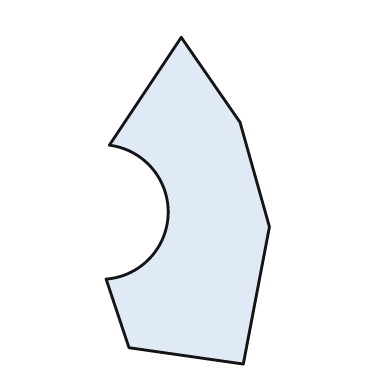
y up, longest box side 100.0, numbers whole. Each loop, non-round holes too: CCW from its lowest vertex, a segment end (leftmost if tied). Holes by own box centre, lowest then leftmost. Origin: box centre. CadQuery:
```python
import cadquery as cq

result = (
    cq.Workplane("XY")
    .moveTo(17.0, -50.0)
    .lineTo(25.0, -8.0)
    .lineTo(16.0, 24.0)
    .lineTo(-2.0, 50.0)
    .lineTo(-24.0, 17.0)
    .threePointArc((-6.0, -4.0), (-25.0, -24.0))
    .lineTo(-18.0, -45.0)
    .close()
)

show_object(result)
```